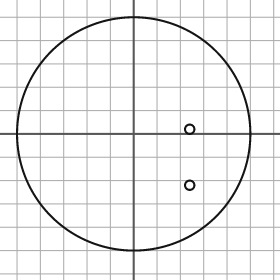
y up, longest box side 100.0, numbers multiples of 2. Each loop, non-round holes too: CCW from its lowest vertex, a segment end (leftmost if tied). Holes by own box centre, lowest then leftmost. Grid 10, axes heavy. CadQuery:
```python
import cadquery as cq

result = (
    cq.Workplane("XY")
    .moveTo(0.0, 0.0)
    .circle(50.0)
    .moveTo(24.0, -22.0)
    .circle(2.0)
    .moveTo(24.0, 2.0)
    .circle(2.0)
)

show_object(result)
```